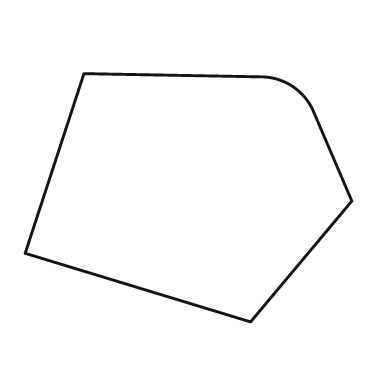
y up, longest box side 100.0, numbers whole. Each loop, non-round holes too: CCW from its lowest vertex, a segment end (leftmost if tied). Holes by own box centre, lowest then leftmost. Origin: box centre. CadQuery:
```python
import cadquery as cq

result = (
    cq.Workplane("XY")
    .moveTo(19.0, -38.0)
    .lineTo(50.0, -1.0)
    .lineTo(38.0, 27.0)
    .threePointArc((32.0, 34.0), (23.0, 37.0))
    .lineTo(-32.0, 38.0)
    .lineTo(-50.0, -17.0)
    .close()
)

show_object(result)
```